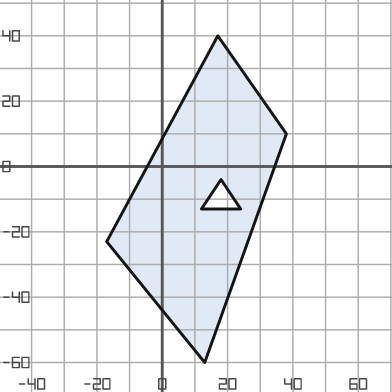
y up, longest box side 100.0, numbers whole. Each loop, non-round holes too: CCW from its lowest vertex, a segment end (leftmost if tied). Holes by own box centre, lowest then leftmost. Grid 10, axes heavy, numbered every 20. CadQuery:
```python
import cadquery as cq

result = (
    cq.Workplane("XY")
    .moveTo(13.0, -60.0)
    .lineTo(38.0, 10.0)
    .lineTo(17.0, 40.0)
    .lineTo(-17.0, -23.0)
    .close()
    .moveTo(12.0, -13.0)
    .lineTo(24.0, -13.0)
    .lineTo(18.0, -4.0)
    .close()
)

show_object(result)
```